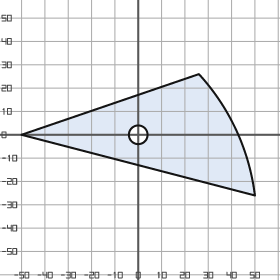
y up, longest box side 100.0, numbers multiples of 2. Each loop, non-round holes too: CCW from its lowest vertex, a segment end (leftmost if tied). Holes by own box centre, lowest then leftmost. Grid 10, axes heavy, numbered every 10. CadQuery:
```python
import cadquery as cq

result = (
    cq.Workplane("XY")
    .moveTo(50.0, -26.0)
    .threePointArc((42.0, 2.0), (26.0, 26.0))
    .lineTo(-50.0, 0.0)
    .close()
    .moveTo(0.0, 0.0)
    .circle(4.0)
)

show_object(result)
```